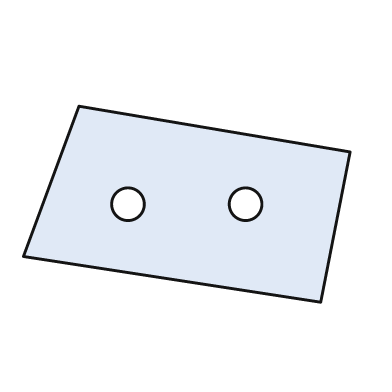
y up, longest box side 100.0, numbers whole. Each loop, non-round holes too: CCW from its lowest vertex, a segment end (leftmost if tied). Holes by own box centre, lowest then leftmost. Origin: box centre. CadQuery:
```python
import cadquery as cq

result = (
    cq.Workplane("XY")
    .moveTo(41.0, -30.0)
    .lineTo(50.0, 16.0)
    .lineTo(-33.0, 30.0)
    .lineTo(-50.0, -16.0)
    .close()
    .moveTo(-18.0, 0.0)
    .circle(5.0)
    .moveTo(18.0, 0.0)
    .circle(5.0)
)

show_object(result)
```